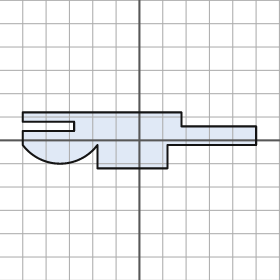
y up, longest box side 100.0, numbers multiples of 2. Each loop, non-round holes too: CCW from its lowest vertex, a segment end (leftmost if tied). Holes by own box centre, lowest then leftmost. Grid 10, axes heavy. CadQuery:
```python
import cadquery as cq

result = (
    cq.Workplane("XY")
    .moveTo(-18.0, -12.0)
    .lineTo(12.0, -12.0)
    .lineTo(12.0, -2.0)
    .lineTo(50.0, -2.0)
    .lineTo(50.0, 6.0)
    .lineTo(18.0, 6.0)
    .lineTo(18.0, 12.0)
    .lineTo(-50.0, 12.0)
    .lineTo(-50.0, 8.0)
    .lineTo(-28.0, 8.0)
    .lineTo(-28.0, 4.0)
    .lineTo(-50.0, 4.0)
    .lineTo(-50.0, -2.0)
    .threePointArc((-34.0, -10.0), (-18.0, -2.0))
    .close()
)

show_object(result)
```